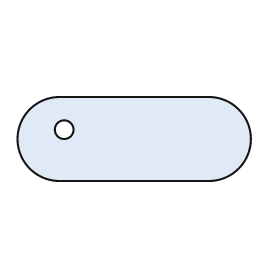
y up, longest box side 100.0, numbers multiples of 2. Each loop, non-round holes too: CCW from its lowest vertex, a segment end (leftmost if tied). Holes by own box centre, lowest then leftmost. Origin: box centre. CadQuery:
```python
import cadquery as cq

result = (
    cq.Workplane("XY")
    .moveTo(-32.0, -18.0)
    .lineTo(32.0, -18.0)
    .threePointArc((50.0, 0.0), (32.0, 18.0))
    .lineTo(-32.0, 18.0)
    .threePointArc((-50.0, 0.0), (-32.0, -18.0))
    .close()
    .moveTo(-30.0, 4.0)
    .circle(4.0)
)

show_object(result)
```